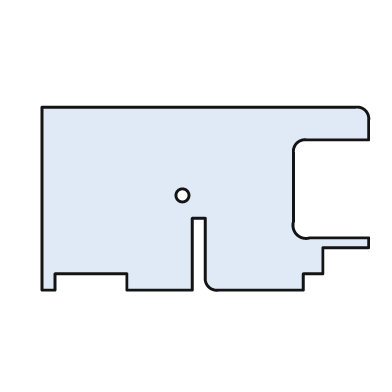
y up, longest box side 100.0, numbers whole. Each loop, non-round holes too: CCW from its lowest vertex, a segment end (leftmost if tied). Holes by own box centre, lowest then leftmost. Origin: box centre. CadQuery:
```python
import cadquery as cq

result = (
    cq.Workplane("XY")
    .moveTo(-50.0, -28.0)
    .lineTo(-46.0, -28.0)
    .lineTo(-46.0, -23.0)
    .lineTo(-24.0, -23.0)
    .lineTo(-24.0, -28.0)
    .lineTo(-4.0, -28.0)
    .lineTo(-4.0, -6.0)
    .lineTo(0.0, -6.0)
    .lineTo(0.0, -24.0)
    .threePointArc((1.0, -27.0), (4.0, -28.0))
    .lineTo(30.0, -28.0)
    .lineTo(30.0, -23.0)
    .lineTo(36.0, -23.0)
    .lineTo(36.0, -15.0)
    .lineTo(50.0, -15.0)
    .lineTo(50.0, -12.0)
    .lineTo(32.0, -12.0)
    .threePointArc((28.0, -11.0), (27.0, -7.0))
    .lineTo(27.0, 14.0)
    .threePointArc((28.0, 17.0), (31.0, 18.0))
    .lineTo(50.0, 18.0)
    .lineTo(50.0, 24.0)
    .threePointArc((49.0, 27.0), (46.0, 28.0))
    .lineTo(-50.0, 28.0)
    .close()
    .moveTo(-7.0, 1.0)
    .circle(2.0)
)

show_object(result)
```